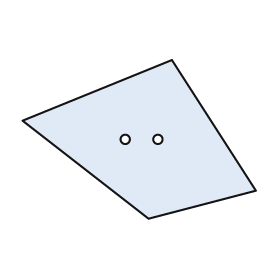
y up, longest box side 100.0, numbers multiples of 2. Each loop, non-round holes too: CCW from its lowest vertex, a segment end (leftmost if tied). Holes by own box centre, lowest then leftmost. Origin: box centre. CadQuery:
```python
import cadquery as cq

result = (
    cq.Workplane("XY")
    .moveTo(4.0, -34.0)
    .lineTo(50.0, -22.0)
    .lineTo(14.0, 34.0)
    .lineTo(-50.0, 8.0)
    .close()
    .moveTo(-6.0, 0.0)
    .circle(2.0)
    .moveTo(8.0, 0.0)
    .circle(2.0)
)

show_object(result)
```